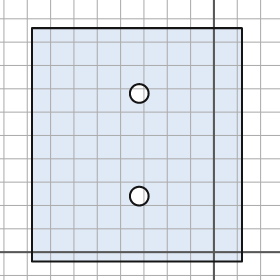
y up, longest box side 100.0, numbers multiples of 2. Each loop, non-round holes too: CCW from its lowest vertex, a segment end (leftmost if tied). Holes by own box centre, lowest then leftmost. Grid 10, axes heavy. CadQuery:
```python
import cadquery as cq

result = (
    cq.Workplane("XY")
    .moveTo(-78.0, -4.0)
    .lineTo(12.0, -4.0)
    .lineTo(12.0, 96.0)
    .lineTo(-78.0, 96.0)
    .close()
    .moveTo(-32.0, 24.0)
    .circle(4.0)
    .moveTo(-32.0, 68.0)
    .circle(4.0)
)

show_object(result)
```